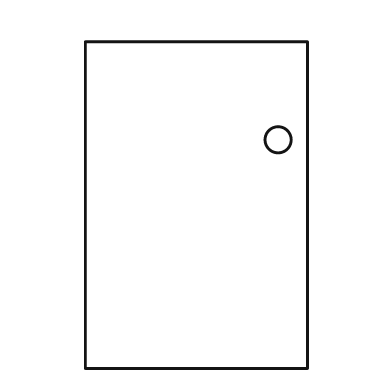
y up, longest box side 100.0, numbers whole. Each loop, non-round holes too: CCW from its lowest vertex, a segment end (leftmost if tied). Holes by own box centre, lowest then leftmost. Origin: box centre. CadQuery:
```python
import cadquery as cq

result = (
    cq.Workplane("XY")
    .moveTo(-34.0, -50.0)
    .lineTo(34.0, -50.0)
    .lineTo(34.0, 50.0)
    .lineTo(-34.0, 50.0)
    .close()
    .moveTo(25.0, 20.0)
    .circle(4.0)
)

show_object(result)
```